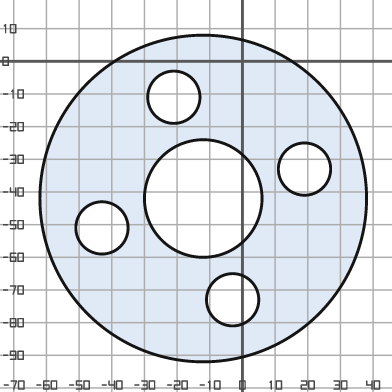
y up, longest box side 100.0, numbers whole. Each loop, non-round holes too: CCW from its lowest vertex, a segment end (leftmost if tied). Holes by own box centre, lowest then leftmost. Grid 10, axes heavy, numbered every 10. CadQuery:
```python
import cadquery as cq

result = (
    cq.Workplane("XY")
    .moveTo(-12.0, -42.0)
    .circle(50.0)
    .moveTo(-3.0, -73.0)
    .circle(8.0)
    .moveTo(-43.0, -51.0)
    .circle(8.0)
    .moveTo(-12.0, -42.0)
    .circle(18.0)
    .moveTo(19.0, -33.0)
    .circle(8.0)
    .moveTo(-21.0, -11.0)
    .circle(8.0)
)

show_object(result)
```